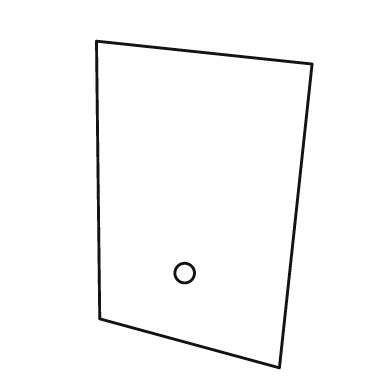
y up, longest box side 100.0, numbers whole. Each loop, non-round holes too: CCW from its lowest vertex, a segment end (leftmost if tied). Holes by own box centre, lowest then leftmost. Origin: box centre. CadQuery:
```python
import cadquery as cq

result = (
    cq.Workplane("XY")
    .moveTo(23.0, -50.0)
    .lineTo(33.0, 43.0)
    .lineTo(-33.0, 50.0)
    .lineTo(-32.0, -35.0)
    .close()
    .moveTo(-6.0, -21.0)
    .circle(3.0)
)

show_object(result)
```